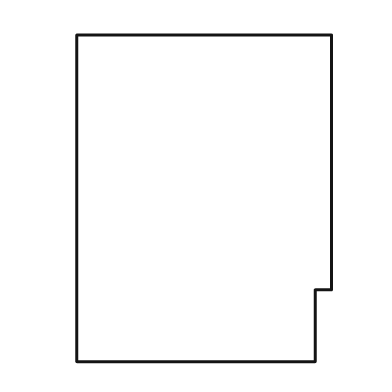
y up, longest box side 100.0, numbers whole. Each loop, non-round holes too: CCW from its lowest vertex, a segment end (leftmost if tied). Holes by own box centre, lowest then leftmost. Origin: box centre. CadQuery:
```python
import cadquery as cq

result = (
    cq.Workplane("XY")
    .moveTo(-39.0, -50.0)
    .lineTo(34.0, -50.0)
    .lineTo(34.0, -28.0)
    .lineTo(39.0, -28.0)
    .lineTo(39.0, 50.0)
    .lineTo(-39.0, 50.0)
    .close()
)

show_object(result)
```